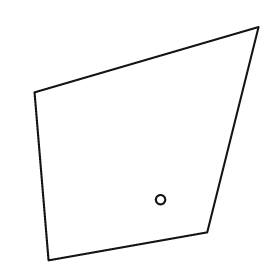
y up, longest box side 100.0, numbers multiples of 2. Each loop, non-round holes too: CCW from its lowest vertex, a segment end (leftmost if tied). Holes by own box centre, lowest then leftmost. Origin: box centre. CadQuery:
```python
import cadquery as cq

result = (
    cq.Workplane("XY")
    .moveTo(-42.0, -50.0)
    .lineTo(26.0, -38.0)
    .lineTo(48.0, 50.0)
    .lineTo(-48.0, 22.0)
    .close()
    .moveTo(6.0, -24.0)
    .circle(2.0)
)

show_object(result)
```